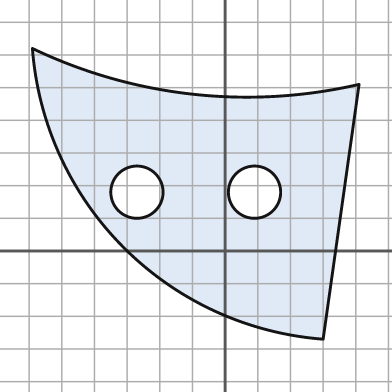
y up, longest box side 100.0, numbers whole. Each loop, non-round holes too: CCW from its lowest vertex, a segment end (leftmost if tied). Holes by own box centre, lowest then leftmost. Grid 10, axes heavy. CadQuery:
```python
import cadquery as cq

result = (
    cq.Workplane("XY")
    .moveTo(30.0, -27.0)
    .lineTo(41.0, 51.0)
    .threePointArc((-10.0, 48.0), (-59.0, 62.0))
    .threePointArc((-31.0, 1.0), (30.0, -27.0))
    .close()
    .moveTo(-27.0, 18.0)
    .circle(8.0)
    .moveTo(9.0, 18.0)
    .circle(8.0)
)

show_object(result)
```